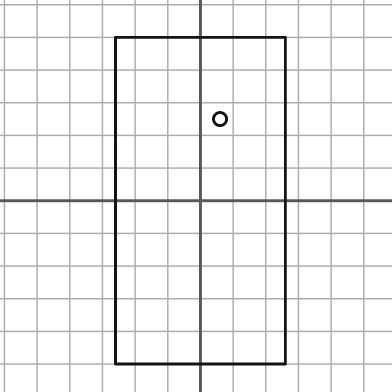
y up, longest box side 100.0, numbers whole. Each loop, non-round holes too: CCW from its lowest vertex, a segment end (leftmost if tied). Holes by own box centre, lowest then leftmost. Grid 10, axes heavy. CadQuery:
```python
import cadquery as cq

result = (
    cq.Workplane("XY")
    .moveTo(-26.0, -50.0)
    .lineTo(26.0, -50.0)
    .lineTo(26.0, 50.0)
    .lineTo(-26.0, 50.0)
    .close()
    .moveTo(6.0, 25.0)
    .circle(2.0)
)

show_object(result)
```